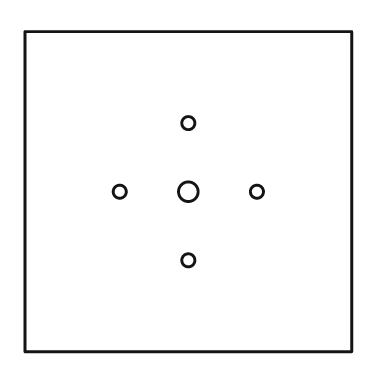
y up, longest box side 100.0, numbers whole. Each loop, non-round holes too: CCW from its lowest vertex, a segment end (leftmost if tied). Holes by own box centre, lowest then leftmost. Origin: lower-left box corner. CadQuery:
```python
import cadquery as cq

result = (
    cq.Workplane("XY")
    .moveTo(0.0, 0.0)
    .lineTo(100.0, 0.0)
    .lineTo(100.0, 98.0)
    .lineTo(0.0, 98.0)
    .close()
    .moveTo(50.0, 28.0)
    .circle(2.0)
    .moveTo(29.0, 49.0)
    .circle(2.0)
    .moveTo(50.0, 49.0)
    .circle(3.0)
    .moveTo(71.0, 49.0)
    .circle(2.0)
    .moveTo(50.0, 70.0)
    .circle(2.0)
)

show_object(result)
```